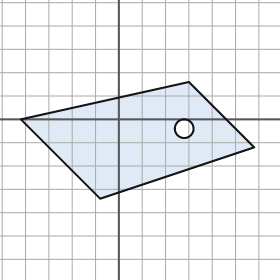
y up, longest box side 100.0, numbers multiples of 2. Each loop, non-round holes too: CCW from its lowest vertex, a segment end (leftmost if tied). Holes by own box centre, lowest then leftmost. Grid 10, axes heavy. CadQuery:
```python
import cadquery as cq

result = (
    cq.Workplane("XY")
    .moveTo(-8.0, -34.0)
    .lineTo(58.0, -12.0)
    .lineTo(30.0, 16.0)
    .lineTo(-42.0, 0.0)
    .close()
    .moveTo(28.0, -4.0)
    .circle(4.0)
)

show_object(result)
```